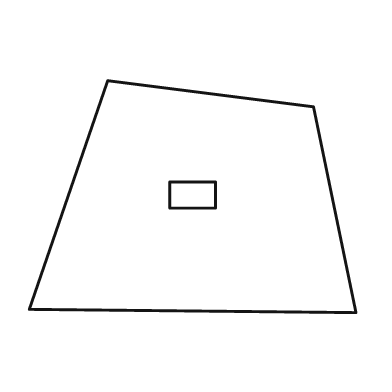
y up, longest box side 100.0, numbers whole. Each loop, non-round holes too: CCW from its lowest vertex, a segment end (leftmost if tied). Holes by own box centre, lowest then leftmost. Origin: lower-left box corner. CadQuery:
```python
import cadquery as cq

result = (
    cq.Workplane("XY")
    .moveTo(100.0, 0.0)
    .lineTo(87.0, 63.0)
    .lineTo(24.0, 71.0)
    .lineTo(0.0, 1.0)
    .close()
    .moveTo(43.0, 32.0)
    .lineTo(57.0, 32.0)
    .lineTo(57.0, 40.0)
    .lineTo(43.0, 40.0)
    .close()
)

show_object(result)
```